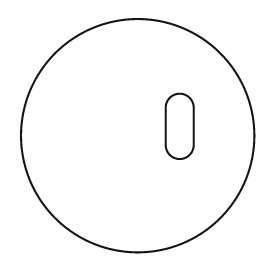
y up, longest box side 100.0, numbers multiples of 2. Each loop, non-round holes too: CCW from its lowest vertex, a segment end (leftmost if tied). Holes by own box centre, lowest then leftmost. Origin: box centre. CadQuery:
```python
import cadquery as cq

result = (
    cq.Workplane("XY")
    .moveTo(0.0, 0.0)
    .circle(50.0)
    .moveTo(12.0, -4.0)
    .threePointArc((18.0, -10.0), (24.0, -4.0))
    .lineTo(24.0, 12.0)
    .threePointArc((18.0, 18.0), (12.0, 12.0))
    .close()
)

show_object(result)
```